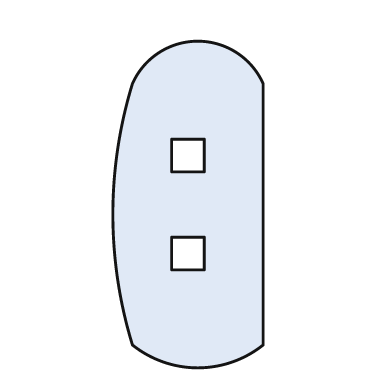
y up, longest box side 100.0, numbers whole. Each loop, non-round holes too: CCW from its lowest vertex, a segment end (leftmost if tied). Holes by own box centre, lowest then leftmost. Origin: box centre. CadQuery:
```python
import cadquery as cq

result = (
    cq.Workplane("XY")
    .moveTo(-17.0, -43.0)
    .threePointArc((3.0, -50.0), (23.0, -43.0))
    .lineTo(23.0, 37.0)
    .threePointArc((3.0, 50.0), (-17.0, 37.0))
    .threePointArc((-23.0, -3.0), (-17.0, -43.0))
    .close()
    .moveTo(-5.0, -20.0)
    .lineTo(5.0, -20.0)
    .lineTo(5.0, -10.0)
    .lineTo(-5.0, -10.0)
    .close()
    .moveTo(-5.0, 10.0)
    .lineTo(5.0, 10.0)
    .lineTo(5.0, 20.0)
    .lineTo(-5.0, 20.0)
    .close()
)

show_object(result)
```